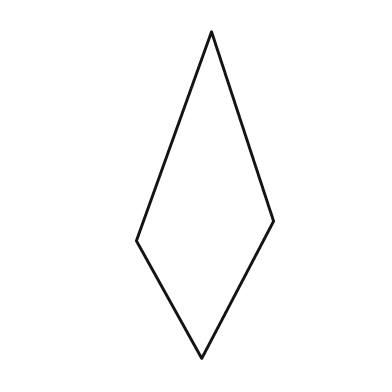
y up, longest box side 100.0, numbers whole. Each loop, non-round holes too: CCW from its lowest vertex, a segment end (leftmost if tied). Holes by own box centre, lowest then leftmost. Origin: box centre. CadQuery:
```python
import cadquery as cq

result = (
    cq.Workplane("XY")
    .moveTo(-1.0, -50.0)
    .lineTo(21.0, -8.0)
    .lineTo(2.0, 50.0)
    .lineTo(-21.0, -14.0)
    .close()
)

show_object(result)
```